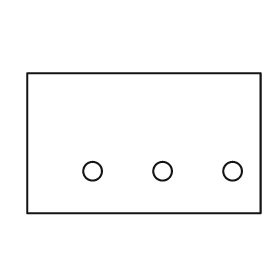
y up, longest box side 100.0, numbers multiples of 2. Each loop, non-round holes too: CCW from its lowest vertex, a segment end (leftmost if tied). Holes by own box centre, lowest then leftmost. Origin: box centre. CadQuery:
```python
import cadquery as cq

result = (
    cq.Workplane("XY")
    .moveTo(-50.0, -30.0)
    .lineTo(50.0, -30.0)
    .lineTo(50.0, 30.0)
    .lineTo(-50.0, 30.0)
    .close()
    .moveTo(-22.0, -12.0)
    .circle(4.0)
    .moveTo(8.0, -12.0)
    .circle(4.0)
    .moveTo(38.0, -12.0)
    .circle(4.0)
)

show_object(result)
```